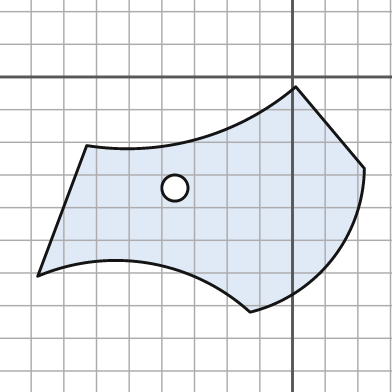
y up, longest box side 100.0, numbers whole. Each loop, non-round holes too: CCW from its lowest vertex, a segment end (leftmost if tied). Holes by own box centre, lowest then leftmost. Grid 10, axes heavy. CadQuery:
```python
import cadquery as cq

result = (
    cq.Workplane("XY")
    .moveTo(-13.0, -72.0)
    .threePointArc((12.0, -56.0), (22.0, -28.0))
    .lineTo(1.0, -3.0)
    .threePointArc((-29.0, -19.0), (-63.0, -21.0))
    .lineTo(-78.0, -61.0)
    .threePointArc((-44.0, -57.0), (-13.0, -72.0))
    .close()
    .moveTo(-36.0, -34.0)
    .circle(4.0)
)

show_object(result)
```